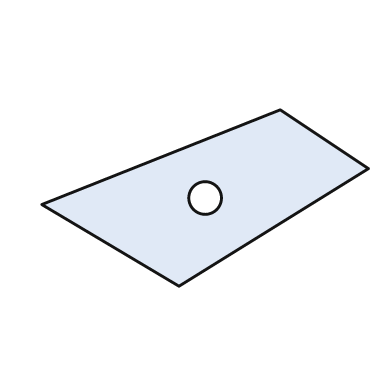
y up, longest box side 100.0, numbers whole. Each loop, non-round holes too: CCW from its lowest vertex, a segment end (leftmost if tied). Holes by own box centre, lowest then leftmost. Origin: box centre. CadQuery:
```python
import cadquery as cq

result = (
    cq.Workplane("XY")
    .moveTo(-8.0, -27.0)
    .lineTo(50.0, 9.0)
    .lineTo(23.0, 27.0)
    .lineTo(-50.0, -2.0)
    .close()
    .moveTo(0.0, 0.0)
    .circle(5.0)
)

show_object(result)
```